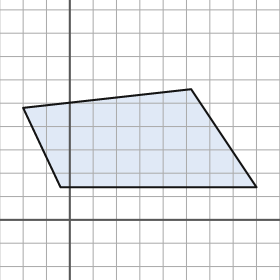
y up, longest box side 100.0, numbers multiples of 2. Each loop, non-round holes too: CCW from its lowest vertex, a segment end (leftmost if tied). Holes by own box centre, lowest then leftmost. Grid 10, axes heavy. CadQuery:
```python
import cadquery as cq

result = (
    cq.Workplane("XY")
    .moveTo(-4.0, 14.0)
    .lineTo(80.0, 14.0)
    .lineTo(52.0, 56.0)
    .lineTo(-20.0, 48.0)
    .close()
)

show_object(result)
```